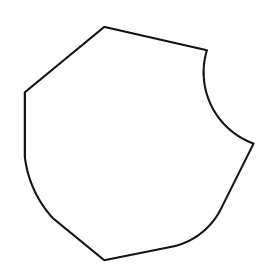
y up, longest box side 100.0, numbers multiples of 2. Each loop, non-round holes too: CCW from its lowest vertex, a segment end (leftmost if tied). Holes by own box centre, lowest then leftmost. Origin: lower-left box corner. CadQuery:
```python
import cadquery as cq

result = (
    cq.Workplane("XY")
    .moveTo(34.0, 0.0)
    .lineTo(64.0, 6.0)
    .threePointArc((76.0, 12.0), (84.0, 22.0))
    .lineTo(98.0, 50.0)
    .threePointArc((80.0, 66.0), (78.0, 90.0))
    .lineTo(34.0, 100.0)
    .lineTo(0.0, 72.0)
    .lineTo(0.0, 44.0)
    .threePointArc((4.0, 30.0), (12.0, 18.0))
    .close()
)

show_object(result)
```